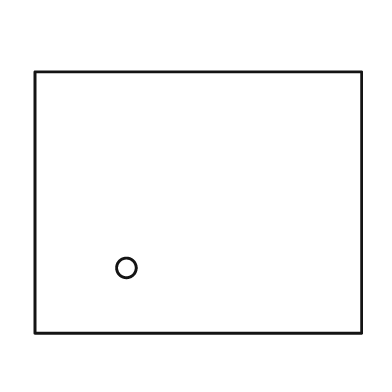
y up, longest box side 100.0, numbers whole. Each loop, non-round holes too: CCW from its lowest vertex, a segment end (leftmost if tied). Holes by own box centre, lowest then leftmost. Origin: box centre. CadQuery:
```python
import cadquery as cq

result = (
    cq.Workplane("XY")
    .moveTo(-50.0, -40.0)
    .lineTo(50.0, -40.0)
    .lineTo(50.0, 40.0)
    .lineTo(-50.0, 40.0)
    .close()
    .moveTo(-22.0, -20.0)
    .circle(3.0)
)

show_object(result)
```